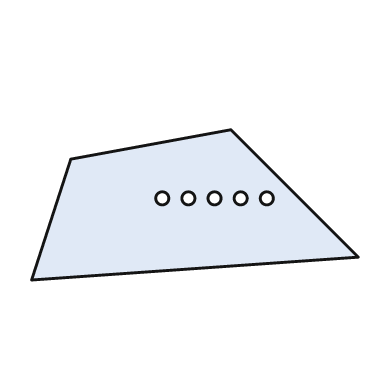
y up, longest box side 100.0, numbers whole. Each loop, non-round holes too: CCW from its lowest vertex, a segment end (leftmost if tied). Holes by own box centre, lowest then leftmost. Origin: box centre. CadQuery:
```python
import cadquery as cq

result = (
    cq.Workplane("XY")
    .moveTo(-50.0, -23.0)
    .lineTo(50.0, -16.0)
    .lineTo(11.0, 23.0)
    .lineTo(-38.0, 14.0)
    .close()
    .moveTo(-10.0, 2.0)
    .circle(2.0)
    .moveTo(-2.0, 2.0)
    .circle(2.0)
    .moveTo(6.0, 2.0)
    .circle(2.0)
    .moveTo(14.0, 2.0)
    .circle(2.0)
    .moveTo(22.0, 2.0)
    .circle(2.0)
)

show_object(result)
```